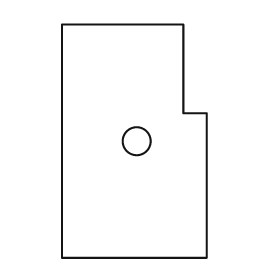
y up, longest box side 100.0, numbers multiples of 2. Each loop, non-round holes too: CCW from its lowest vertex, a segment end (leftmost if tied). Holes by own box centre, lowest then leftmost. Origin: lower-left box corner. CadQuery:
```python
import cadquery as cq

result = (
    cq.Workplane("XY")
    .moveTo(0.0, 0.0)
    .lineTo(62.0, 0.0)
    .lineTo(62.0, 62.0)
    .lineTo(52.0, 62.0)
    .lineTo(52.0, 100.0)
    .lineTo(0.0, 100.0)
    .close()
    .moveTo(32.0, 50.0)
    .circle(6.0)
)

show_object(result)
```